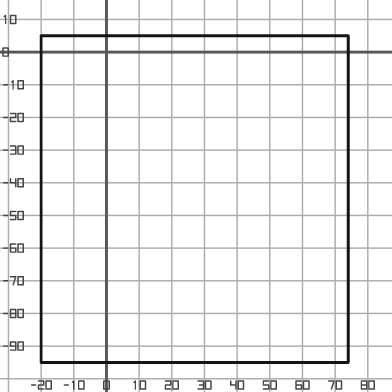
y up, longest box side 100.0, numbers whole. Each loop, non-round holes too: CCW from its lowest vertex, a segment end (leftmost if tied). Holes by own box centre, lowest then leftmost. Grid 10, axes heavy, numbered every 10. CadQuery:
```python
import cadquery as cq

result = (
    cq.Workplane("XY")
    .moveTo(-20.0, -95.0)
    .lineTo(74.0, -95.0)
    .lineTo(74.0, 5.0)
    .lineTo(-20.0, 5.0)
    .close()
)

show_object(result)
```